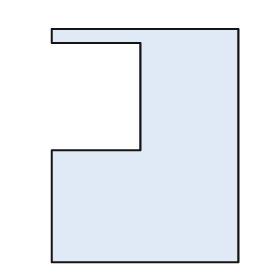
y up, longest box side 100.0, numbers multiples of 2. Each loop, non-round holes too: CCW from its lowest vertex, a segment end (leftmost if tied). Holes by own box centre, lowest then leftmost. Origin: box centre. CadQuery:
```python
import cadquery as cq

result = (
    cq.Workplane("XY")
    .moveTo(-40.0, -50.0)
    .lineTo(40.0, -50.0)
    .lineTo(40.0, 50.0)
    .lineTo(-40.0, 50.0)
    .lineTo(-40.0, 44.0)
    .lineTo(-2.0, 44.0)
    .lineTo(-2.0, -2.0)
    .lineTo(-40.0, -2.0)
    .close()
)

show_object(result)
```